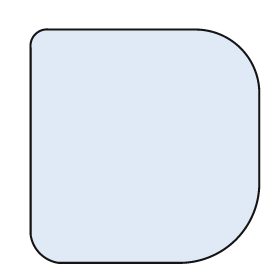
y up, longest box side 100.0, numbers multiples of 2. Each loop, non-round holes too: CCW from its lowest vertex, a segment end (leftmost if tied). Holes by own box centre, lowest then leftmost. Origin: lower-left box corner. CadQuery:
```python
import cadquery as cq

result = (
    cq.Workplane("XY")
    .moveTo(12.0, 0.0)
    .lineTo(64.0, 0.0)
    .threePointArc((88.0, 10.0), (98.0, 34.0))
    .lineTo(98.0, 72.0)
    .threePointArc((90.0, 92.0), (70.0, 100.0))
    .lineTo(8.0, 100.0)
    .threePointArc((2.0, 98.0), (0.0, 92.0))
    .lineTo(0.0, 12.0)
    .threePointArc((4.0, 4.0), (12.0, 0.0))
    .close()
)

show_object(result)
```